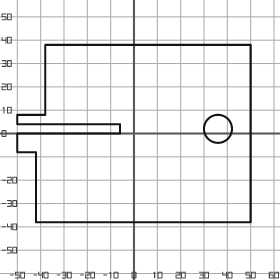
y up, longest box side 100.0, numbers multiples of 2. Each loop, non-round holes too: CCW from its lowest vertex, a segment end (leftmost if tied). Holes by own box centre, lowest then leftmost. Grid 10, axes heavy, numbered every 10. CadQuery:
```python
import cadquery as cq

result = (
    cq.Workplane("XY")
    .moveTo(-42.0, -38.0)
    .lineTo(50.0, -38.0)
    .lineTo(50.0, 38.0)
    .lineTo(-38.0, 38.0)
    .lineTo(-38.0, 8.0)
    .lineTo(-50.0, 8.0)
    .lineTo(-50.0, 4.0)
    .lineTo(-6.0, 4.0)
    .lineTo(-6.0, 0.0)
    .lineTo(-50.0, 0.0)
    .lineTo(-50.0, -8.0)
    .lineTo(-42.0, -8.0)
    .close()
    .moveTo(36.0, 2.0)
    .circle(6.0)
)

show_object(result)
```